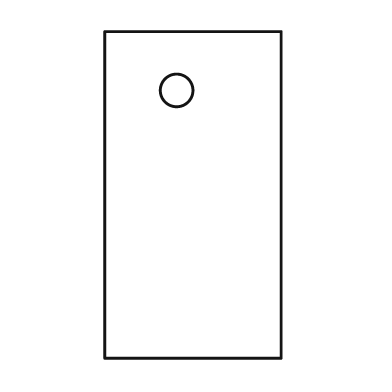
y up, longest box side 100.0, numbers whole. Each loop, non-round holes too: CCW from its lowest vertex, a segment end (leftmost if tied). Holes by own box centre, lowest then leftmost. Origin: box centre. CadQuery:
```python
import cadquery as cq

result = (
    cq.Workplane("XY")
    .moveTo(-27.0, -50.0)
    .lineTo(27.0, -50.0)
    .lineTo(27.0, 50.0)
    .lineTo(-27.0, 50.0)
    .close()
    .moveTo(-5.0, 32.0)
    .circle(5.0)
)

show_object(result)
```